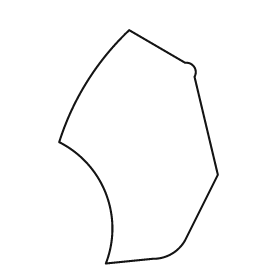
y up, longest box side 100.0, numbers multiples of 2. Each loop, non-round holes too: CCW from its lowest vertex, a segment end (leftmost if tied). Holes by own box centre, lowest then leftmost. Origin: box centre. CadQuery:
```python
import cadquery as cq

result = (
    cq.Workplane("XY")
    .moveTo(-14.0, -50.0)
    .lineTo(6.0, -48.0)
    .threePointArc((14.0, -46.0), (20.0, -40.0))
    .lineTo(34.0, -12.0)
    .lineTo(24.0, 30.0)
    .threePointArc((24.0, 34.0), (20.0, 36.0))
    .lineTo(-4.0, 50.0)
    .threePointArc((-22.0, 28.0), (-34.0, 2.0))
    .threePointArc((-14.0, -20.0), (-14.0, -50.0))
    .close()
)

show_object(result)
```